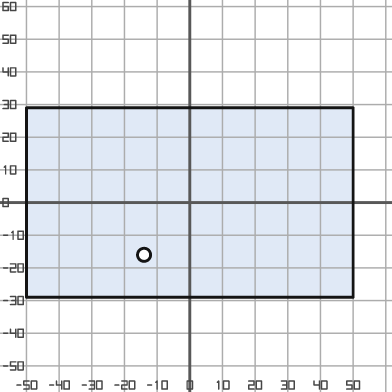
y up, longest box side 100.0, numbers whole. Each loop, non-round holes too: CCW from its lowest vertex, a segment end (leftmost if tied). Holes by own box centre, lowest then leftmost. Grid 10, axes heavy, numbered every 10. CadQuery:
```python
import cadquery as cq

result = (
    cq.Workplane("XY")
    .moveTo(-50.0, -29.0)
    .lineTo(50.0, -29.0)
    .lineTo(50.0, 29.0)
    .lineTo(-50.0, 29.0)
    .close()
    .moveTo(-14.0, -16.0)
    .circle(2.0)
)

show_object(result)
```